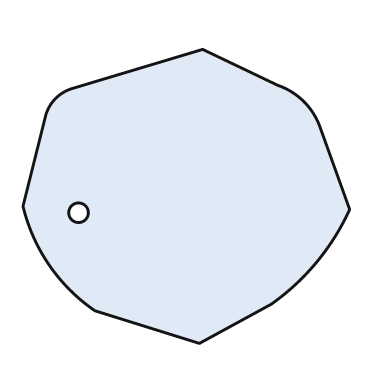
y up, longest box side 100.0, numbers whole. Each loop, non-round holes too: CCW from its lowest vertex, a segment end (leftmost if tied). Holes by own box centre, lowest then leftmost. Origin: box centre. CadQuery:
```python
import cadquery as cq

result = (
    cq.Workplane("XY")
    .moveTo(4.0, -45.0)
    .lineTo(26.0, -33.0)
    .threePointArc((40.0, -20.0), (50.0, -4.0))
    .lineTo(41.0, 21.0)
    .threePointArc((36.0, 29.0), (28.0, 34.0))
    .lineTo(5.0, 45.0)
    .lineTo(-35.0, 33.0)
    .threePointArc((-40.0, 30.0), (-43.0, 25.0))
    .lineTo(-50.0, -3.0)
    .threePointArc((-42.0, -21.0), (-28.0, -35.0))
    .close()
    .moveTo(-33.0, -5.0)
    .circle(3.0)
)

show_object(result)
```